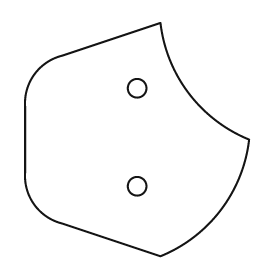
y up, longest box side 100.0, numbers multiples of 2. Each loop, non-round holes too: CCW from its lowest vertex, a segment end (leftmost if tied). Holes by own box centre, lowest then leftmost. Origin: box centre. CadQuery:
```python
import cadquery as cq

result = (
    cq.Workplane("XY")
    .moveTo(10.0, -50.0)
    .threePointArc((36.0, -30.0), (48.0, 0.0))
    .threePointArc((22.0, 20.0), (10.0, 50.0))
    .lineTo(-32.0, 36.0)
    .threePointArc((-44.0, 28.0), (-48.0, 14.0))
    .lineTo(-48.0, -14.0)
    .threePointArc((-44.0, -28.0), (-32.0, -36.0))
    .close()
    .moveTo(0.0, -20.0)
    .circle(4.0)
    .moveTo(0.0, 22.0)
    .circle(4.0)
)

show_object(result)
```